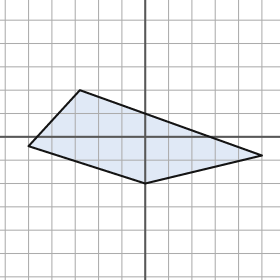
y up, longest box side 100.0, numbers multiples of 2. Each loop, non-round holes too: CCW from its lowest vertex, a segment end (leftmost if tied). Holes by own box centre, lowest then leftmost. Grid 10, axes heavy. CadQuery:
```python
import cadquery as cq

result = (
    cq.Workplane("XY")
    .moveTo(0.0, -20.0)
    .lineTo(50.0, -8.0)
    .lineTo(-28.0, 20.0)
    .lineTo(-50.0, -4.0)
    .close()
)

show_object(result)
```